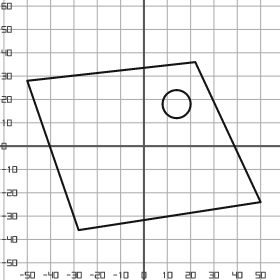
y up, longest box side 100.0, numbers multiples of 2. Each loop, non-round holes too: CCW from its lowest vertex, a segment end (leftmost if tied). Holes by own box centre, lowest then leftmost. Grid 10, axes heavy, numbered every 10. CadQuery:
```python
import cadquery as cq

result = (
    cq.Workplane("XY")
    .moveTo(-28.0, -36.0)
    .lineTo(50.0, -24.0)
    .lineTo(22.0, 36.0)
    .lineTo(-50.0, 28.0)
    .close()
    .moveTo(14.0, 18.0)
    .circle(6.0)
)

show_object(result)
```